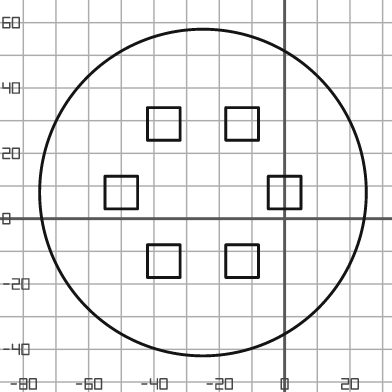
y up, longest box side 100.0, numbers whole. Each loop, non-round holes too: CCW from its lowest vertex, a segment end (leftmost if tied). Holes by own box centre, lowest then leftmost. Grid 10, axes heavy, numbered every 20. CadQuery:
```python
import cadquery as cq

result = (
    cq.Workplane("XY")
    .moveTo(-25.0, 8.0)
    .circle(50.0)
    .moveTo(-42.0, -18.0)
    .lineTo(-32.0, -18.0)
    .lineTo(-32.0, -8.0)
    .lineTo(-42.0, -8.0)
    .close()
    .moveTo(-18.0, -18.0)
    .lineTo(-8.0, -18.0)
    .lineTo(-8.0, -8.0)
    .lineTo(-18.0, -8.0)
    .close()
    .moveTo(-55.0, 3.0)
    .lineTo(-45.0, 3.0)
    .lineTo(-45.0, 13.0)
    .lineTo(-55.0, 13.0)
    .close()
    .moveTo(-5.0, 3.0)
    .lineTo(5.0, 3.0)
    .lineTo(5.0, 13.0)
    .lineTo(-5.0, 13.0)
    .close()
    .moveTo(-42.0, 24.0)
    .lineTo(-32.0, 24.0)
    .lineTo(-32.0, 34.0)
    .lineTo(-42.0, 34.0)
    .close()
    .moveTo(-18.0, 24.0)
    .lineTo(-8.0, 24.0)
    .lineTo(-8.0, 34.0)
    .lineTo(-18.0, 34.0)
    .close()
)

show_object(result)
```